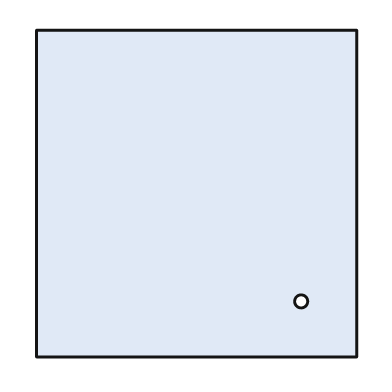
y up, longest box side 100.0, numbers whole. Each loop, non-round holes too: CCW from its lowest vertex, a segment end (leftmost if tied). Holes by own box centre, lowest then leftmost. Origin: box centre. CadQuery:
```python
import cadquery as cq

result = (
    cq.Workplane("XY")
    .moveTo(-49.0, -50.0)
    .lineTo(49.0, -50.0)
    .lineTo(49.0, 50.0)
    .lineTo(-49.0, 50.0)
    .close()
    .moveTo(32.0, -33.0)
    .circle(2.0)
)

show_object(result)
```